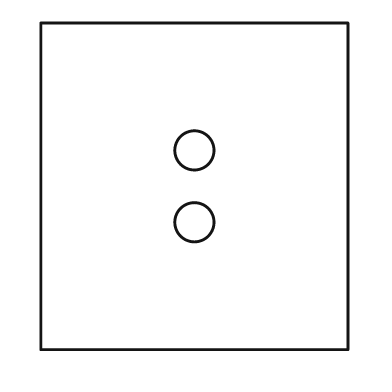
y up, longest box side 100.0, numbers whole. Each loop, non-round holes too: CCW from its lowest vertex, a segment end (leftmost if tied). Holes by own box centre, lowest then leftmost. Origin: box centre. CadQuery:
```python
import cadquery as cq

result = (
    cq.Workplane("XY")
    .moveTo(-47.0, -50.0)
    .lineTo(47.0, -50.0)
    .lineTo(47.0, 50.0)
    .lineTo(-47.0, 50.0)
    .close()
    .moveTo(0.0, -11.0)
    .circle(6.0)
    .moveTo(0.0, 11.0)
    .circle(6.0)
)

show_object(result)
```